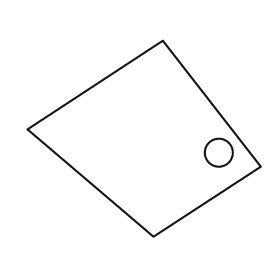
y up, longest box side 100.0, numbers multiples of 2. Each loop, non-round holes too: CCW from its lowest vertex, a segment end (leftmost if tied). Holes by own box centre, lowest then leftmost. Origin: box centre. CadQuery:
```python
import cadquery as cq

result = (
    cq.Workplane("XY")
    .moveTo(4.0, -42.0)
    .lineTo(50.0, -12.0)
    .lineTo(8.0, 42.0)
    .lineTo(-50.0, 4.0)
    .close()
    .moveTo(32.0, -6.0)
    .circle(6.0)
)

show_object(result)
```